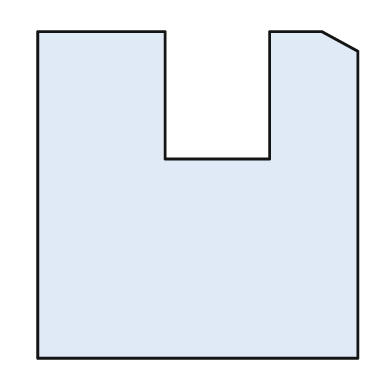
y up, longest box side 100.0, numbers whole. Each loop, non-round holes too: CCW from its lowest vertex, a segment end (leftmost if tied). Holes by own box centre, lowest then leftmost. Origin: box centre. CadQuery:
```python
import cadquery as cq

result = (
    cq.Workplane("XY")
    .moveTo(-49.0, -50.0)
    .lineTo(49.0, -50.0)
    .lineTo(49.0, 44.0)
    .lineTo(38.0, 50.0)
    .lineTo(22.0, 50.0)
    .lineTo(22.0, 11.0)
    .lineTo(-10.0, 11.0)
    .lineTo(-10.0, 50.0)
    .lineTo(-49.0, 50.0)
    .close()
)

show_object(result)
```